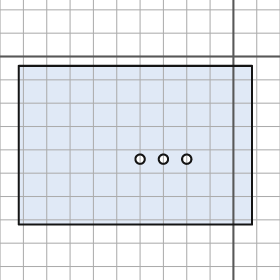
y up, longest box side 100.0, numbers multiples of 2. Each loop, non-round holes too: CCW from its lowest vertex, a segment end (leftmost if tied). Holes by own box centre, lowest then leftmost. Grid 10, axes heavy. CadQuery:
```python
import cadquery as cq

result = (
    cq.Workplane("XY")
    .moveTo(-92.0, -72.0)
    .lineTo(8.0, -72.0)
    .lineTo(8.0, -4.0)
    .lineTo(-92.0, -4.0)
    .close()
    .moveTo(-40.0, -44.0)
    .circle(2.0)
    .moveTo(-30.0, -44.0)
    .circle(2.0)
    .moveTo(-20.0, -44.0)
    .circle(2.0)
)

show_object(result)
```